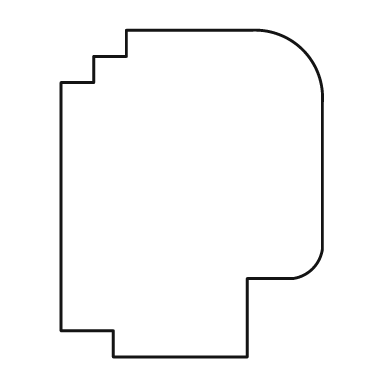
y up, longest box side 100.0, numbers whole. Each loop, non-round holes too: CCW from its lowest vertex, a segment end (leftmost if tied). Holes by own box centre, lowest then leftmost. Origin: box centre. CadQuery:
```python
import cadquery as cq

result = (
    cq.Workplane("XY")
    .moveTo(-24.0, -50.0)
    .lineTo(17.0, -50.0)
    .lineTo(17.0, -26.0)
    .lineTo(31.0, -26.0)
    .threePointArc((37.0, -23.0), (40.0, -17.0))
    .lineTo(40.0, 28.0)
    .threePointArc((34.0, 44.0), (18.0, 50.0))
    .lineTo(-20.0, 50.0)
    .lineTo(-20.0, 42.0)
    .lineTo(-30.0, 42.0)
    .lineTo(-30.0, 34.0)
    .lineTo(-40.0, 34.0)
    .lineTo(-40.0, -42.0)
    .lineTo(-24.0, -42.0)
    .close()
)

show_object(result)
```